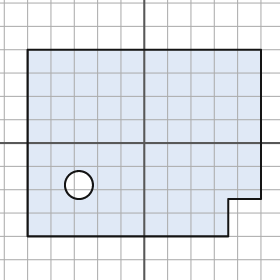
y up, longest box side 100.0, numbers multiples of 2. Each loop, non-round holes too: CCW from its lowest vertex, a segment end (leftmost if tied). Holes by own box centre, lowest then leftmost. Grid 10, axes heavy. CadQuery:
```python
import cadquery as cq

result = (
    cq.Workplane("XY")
    .moveTo(-50.0, -40.0)
    .lineTo(36.0, -40.0)
    .lineTo(36.0, -24.0)
    .lineTo(50.0, -24.0)
    .lineTo(50.0, 40.0)
    .lineTo(-50.0, 40.0)
    .close()
    .moveTo(-28.0, -18.0)
    .circle(6.0)
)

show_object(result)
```